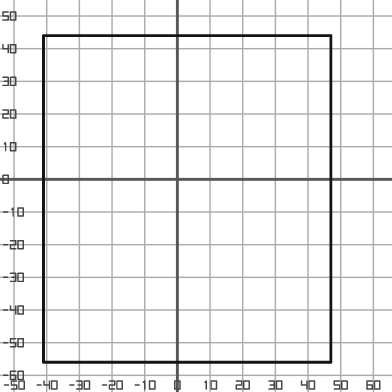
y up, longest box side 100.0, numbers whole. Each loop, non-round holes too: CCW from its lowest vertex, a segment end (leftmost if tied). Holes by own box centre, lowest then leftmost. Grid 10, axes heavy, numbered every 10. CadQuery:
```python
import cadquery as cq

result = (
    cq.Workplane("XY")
    .moveTo(-41.0, -56.0)
    .lineTo(47.0, -56.0)
    .lineTo(47.0, 44.0)
    .lineTo(-41.0, 44.0)
    .close()
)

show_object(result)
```